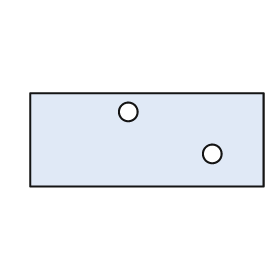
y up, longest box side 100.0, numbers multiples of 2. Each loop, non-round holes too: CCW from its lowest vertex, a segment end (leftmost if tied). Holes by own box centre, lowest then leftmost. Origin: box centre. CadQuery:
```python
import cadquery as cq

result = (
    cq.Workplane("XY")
    .moveTo(-50.0, -20.0)
    .lineTo(50.0, -20.0)
    .lineTo(50.0, 20.0)
    .lineTo(-50.0, 20.0)
    .close()
    .moveTo(28.0, -6.0)
    .circle(4.0)
    .moveTo(-8.0, 12.0)
    .circle(4.0)
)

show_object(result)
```